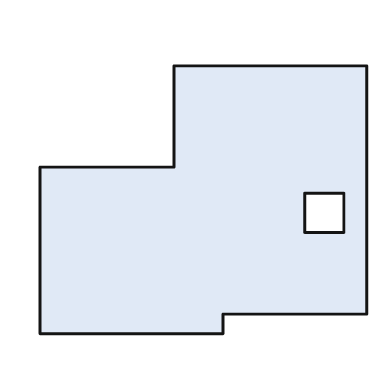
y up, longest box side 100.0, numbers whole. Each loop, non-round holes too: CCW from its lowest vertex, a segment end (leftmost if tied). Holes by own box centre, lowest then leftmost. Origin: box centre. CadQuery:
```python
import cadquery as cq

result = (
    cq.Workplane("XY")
    .moveTo(-50.0, -41.0)
    .lineTo(6.0, -41.0)
    .lineTo(6.0, -35.0)
    .lineTo(50.0, -35.0)
    .lineTo(50.0, 41.0)
    .lineTo(-9.0, 41.0)
    .lineTo(-9.0, 10.0)
    .lineTo(-50.0, 10.0)
    .close()
    .moveTo(31.0, -10.0)
    .lineTo(43.0, -10.0)
    .lineTo(43.0, 2.0)
    .lineTo(31.0, 2.0)
    .close()
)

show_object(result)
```